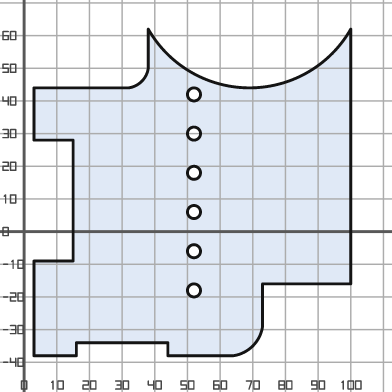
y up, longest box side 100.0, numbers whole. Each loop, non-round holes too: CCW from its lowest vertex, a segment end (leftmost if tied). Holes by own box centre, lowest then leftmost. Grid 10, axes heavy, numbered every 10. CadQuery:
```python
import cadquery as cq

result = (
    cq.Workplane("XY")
    .moveTo(3.0, -38.0)
    .lineTo(16.0, -38.0)
    .lineTo(16.0, -34.0)
    .lineTo(44.0, -34.0)
    .lineTo(44.0, -38.0)
    .lineTo(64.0, -38.0)
    .threePointArc((70.0, -35.0), (73.0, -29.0))
    .lineTo(73.0, -16.0)
    .lineTo(100.0, -16.0)
    .lineTo(100.0, 62.0)
    .threePointArc((69.0, 44.0), (38.0, 62.0))
    .lineTo(38.0, 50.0)
    .threePointArc((36.0, 46.0), (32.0, 44.0))
    .lineTo(3.0, 44.0)
    .lineTo(3.0, 28.0)
    .lineTo(15.0, 28.0)
    .lineTo(15.0, -9.0)
    .lineTo(3.0, -9.0)
    .close()
    .moveTo(52.0, -18.0)
    .circle(2.0)
    .moveTo(52.0, -6.0)
    .circle(2.0)
    .moveTo(52.0, 6.0)
    .circle(2.0)
    .moveTo(52.0, 18.0)
    .circle(2.0)
    .moveTo(52.0, 30.0)
    .circle(2.0)
    .moveTo(52.0, 42.0)
    .circle(2.0)
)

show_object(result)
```